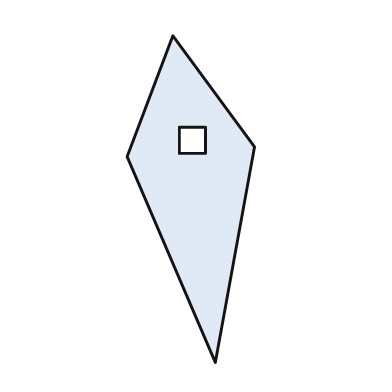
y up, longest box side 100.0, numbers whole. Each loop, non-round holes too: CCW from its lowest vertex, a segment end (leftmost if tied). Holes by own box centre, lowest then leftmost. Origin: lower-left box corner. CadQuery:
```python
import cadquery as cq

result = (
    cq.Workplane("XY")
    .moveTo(27.0, 0.0)
    .lineTo(39.0, 66.0)
    .lineTo(14.0, 100.0)
    .lineTo(0.0, 63.0)
    .close()
    .moveTo(16.0, 64.0)
    .lineTo(24.0, 64.0)
    .lineTo(24.0, 72.0)
    .lineTo(16.0, 72.0)
    .close()
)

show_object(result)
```